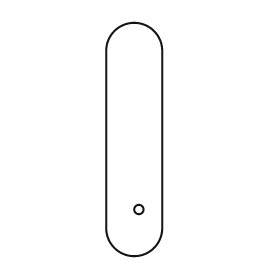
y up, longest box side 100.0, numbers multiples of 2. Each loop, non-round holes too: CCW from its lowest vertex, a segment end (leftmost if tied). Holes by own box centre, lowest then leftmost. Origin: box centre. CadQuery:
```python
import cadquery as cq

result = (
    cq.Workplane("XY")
    .moveTo(-12.0, -38.0)
    .threePointArc((0.0, -50.0), (12.0, -38.0))
    .lineTo(12.0, 38.0)
    .threePointArc((0.0, 50.0), (-12.0, 38.0))
    .close()
    .moveTo(2.0, -30.0)
    .circle(2.0)
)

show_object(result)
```